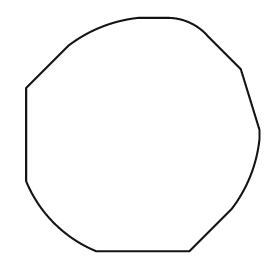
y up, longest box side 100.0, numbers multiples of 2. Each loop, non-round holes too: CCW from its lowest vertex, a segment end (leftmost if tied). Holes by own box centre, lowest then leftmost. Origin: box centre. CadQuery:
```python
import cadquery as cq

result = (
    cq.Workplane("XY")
    .moveTo(-20.0, -50.0)
    .lineTo(20.0, -50.0)
    .lineTo(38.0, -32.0)
    .threePointArc((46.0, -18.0), (50.0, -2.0))
    .lineTo(50.0, 2.0)
    .lineTo(42.0, 28.0)
    .lineTo(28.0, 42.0)
    .threePointArc((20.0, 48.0), (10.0, 50.0))
    .lineTo(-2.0, 50.0)
    .threePointArc((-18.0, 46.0), (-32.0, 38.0))
    .lineTo(-50.0, 20.0)
    .lineTo(-50.0, -20.0)
    .threePointArc((-38.0, -38.0), (-20.0, -50.0))
    .close()
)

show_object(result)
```